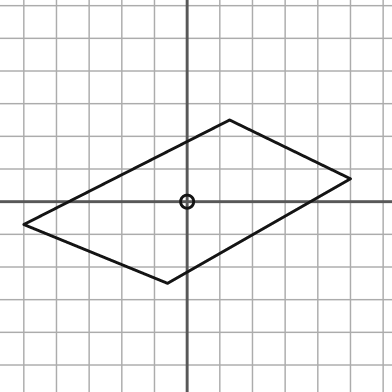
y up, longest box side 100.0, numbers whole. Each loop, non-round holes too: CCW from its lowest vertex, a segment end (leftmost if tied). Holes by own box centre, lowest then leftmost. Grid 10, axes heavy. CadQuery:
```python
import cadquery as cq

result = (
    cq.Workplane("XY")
    .moveTo(-6.0, -25.0)
    .lineTo(50.0, 7.0)
    .lineTo(13.0, 25.0)
    .lineTo(-50.0, -7.0)
    .close()
    .moveTo(0.0, 0.0)
    .circle(2.0)
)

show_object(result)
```